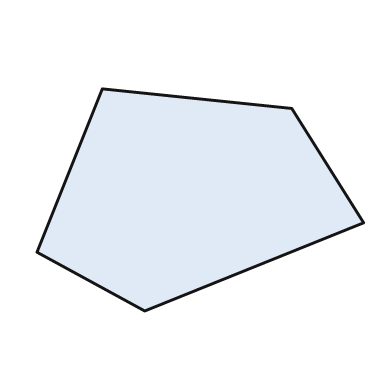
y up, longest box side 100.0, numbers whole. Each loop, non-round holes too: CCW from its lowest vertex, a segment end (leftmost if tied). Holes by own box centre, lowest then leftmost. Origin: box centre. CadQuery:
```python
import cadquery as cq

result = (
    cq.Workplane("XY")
    .moveTo(-17.0, -34.0)
    .lineTo(50.0, -7.0)
    .lineTo(28.0, 28.0)
    .lineTo(-30.0, 34.0)
    .lineTo(-50.0, -16.0)
    .close()
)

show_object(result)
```